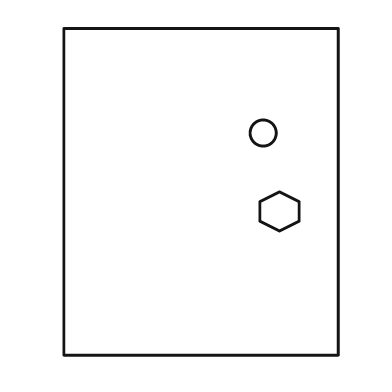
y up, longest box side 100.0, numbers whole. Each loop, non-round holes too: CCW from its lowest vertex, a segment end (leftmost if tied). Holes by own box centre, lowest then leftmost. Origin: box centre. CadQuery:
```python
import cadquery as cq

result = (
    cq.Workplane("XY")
    .moveTo(-42.0, -50.0)
    .lineTo(42.0, -50.0)
    .lineTo(42.0, 50.0)
    .lineTo(-42.0, 50.0)
    .close()
    .moveTo(24.0, -12.0)
    .lineTo(30.0, -9.0)
    .lineTo(30.0, -3.0)
    .lineTo(24.0, 0.0)
    .lineTo(18.0, -3.0)
    .lineTo(18.0, -9.0)
    .close()
    .moveTo(19.0, 18.0)
    .circle(4.0)
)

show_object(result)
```